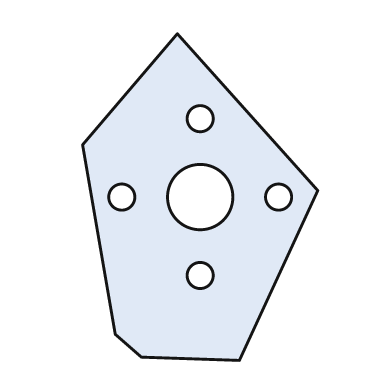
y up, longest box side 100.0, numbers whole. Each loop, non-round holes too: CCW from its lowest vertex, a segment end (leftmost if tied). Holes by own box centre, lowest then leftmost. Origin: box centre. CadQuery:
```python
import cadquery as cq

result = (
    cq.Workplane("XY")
    .moveTo(12.0, -50.0)
    .lineTo(36.0, 2.0)
    .lineTo(-7.0, 50.0)
    .lineTo(-36.0, 16.0)
    .lineTo(-26.0, -42.0)
    .lineTo(-18.0, -49.0)
    .close()
    .moveTo(0.0, -24.0)
    .circle(4.0)
    .moveTo(-24.0, 0.0)
    .circle(4.0)
    .moveTo(0.0, 0.0)
    .circle(10.0)
    .moveTo(24.0, 0.0)
    .circle(4.0)
    .moveTo(0.0, 24.0)
    .circle(4.0)
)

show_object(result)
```